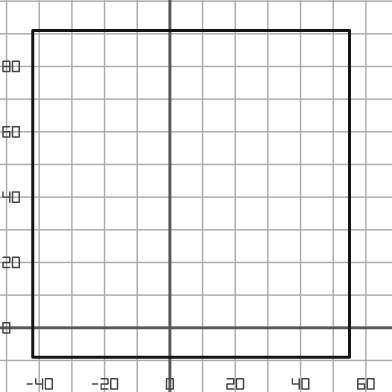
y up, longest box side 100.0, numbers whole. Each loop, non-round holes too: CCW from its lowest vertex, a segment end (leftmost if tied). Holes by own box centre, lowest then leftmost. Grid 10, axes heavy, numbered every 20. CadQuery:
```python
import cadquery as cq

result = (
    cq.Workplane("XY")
    .moveTo(-42.0, -9.0)
    .lineTo(55.0, -9.0)
    .lineTo(55.0, 91.0)
    .lineTo(-42.0, 91.0)
    .close()
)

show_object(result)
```